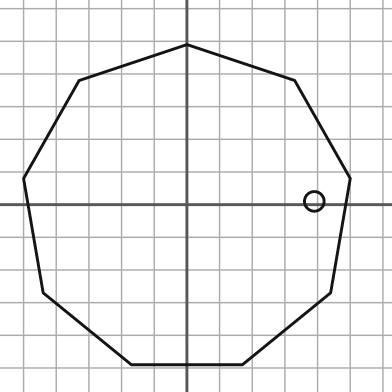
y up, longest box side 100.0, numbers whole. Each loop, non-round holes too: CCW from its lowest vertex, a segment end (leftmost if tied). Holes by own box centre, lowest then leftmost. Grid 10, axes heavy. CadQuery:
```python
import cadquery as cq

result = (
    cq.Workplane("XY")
    .moveTo(-17.0, -49.0)
    .lineTo(17.0, -49.0)
    .lineTo(44.0, -27.0)
    .lineTo(50.0, 8.0)
    .lineTo(33.0, 38.0)
    .lineTo(0.0, 49.0)
    .lineTo(-33.0, 38.0)
    .lineTo(-50.0, 8.0)
    .lineTo(-44.0, -27.0)
    .close()
    .moveTo(39.0, 1.0)
    .circle(3.0)
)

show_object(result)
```